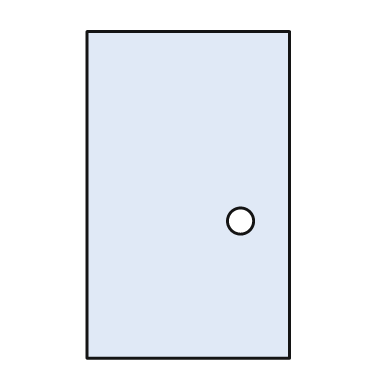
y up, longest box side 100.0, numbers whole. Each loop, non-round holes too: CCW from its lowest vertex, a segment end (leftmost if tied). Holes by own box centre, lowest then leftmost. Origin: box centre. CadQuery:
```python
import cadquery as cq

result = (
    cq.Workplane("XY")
    .moveTo(-31.0, -50.0)
    .lineTo(31.0, -50.0)
    .lineTo(31.0, 50.0)
    .lineTo(-31.0, 50.0)
    .close()
    .moveTo(16.0, -8.0)
    .circle(4.0)
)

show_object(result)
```